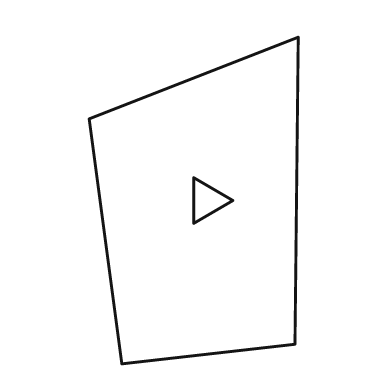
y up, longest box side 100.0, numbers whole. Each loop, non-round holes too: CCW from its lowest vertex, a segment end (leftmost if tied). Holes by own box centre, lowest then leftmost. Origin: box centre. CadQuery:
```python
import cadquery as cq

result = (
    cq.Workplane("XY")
    .moveTo(-22.0, -50.0)
    .lineTo(31.0, -44.0)
    .lineTo(32.0, 50.0)
    .lineTo(-32.0, 25.0)
    .close()
    .moveTo(0.0, -7.0)
    .lineTo(12.0, 0.0)
    .lineTo(0.0, 7.0)
    .close()
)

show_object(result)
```